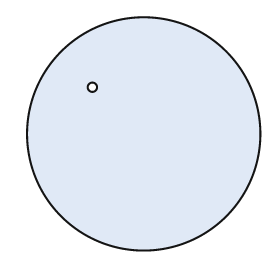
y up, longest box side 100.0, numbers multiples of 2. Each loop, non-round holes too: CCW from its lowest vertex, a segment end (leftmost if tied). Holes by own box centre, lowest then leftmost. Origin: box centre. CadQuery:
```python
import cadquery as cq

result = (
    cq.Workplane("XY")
    .moveTo(0.0, 0.0)
    .circle(50.0)
    .moveTo(-22.0, 20.0)
    .circle(2.0)
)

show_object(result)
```